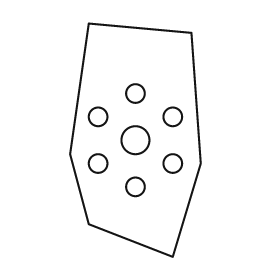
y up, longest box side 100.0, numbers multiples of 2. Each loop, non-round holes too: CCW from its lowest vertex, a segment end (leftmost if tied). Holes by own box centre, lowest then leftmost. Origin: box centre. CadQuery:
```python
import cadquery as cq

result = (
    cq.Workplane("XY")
    .moveTo(16.0, -50.0)
    .lineTo(28.0, -10.0)
    .lineTo(24.0, 46.0)
    .lineTo(-20.0, 50.0)
    .lineTo(-28.0, -6.0)
    .lineTo(-20.0, -36.0)
    .close()
    .moveTo(0.0, -20.0)
    .circle(4.0)
    .moveTo(-16.0, -10.0)
    .circle(4.0)
    .moveTo(16.0, -10.0)
    .circle(4.0)
    .moveTo(0.0, 0.0)
    .circle(6.0)
    .moveTo(-16.0, 10.0)
    .circle(4.0)
    .moveTo(16.0, 10.0)
    .circle(4.0)
    .moveTo(0.0, 20.0)
    .circle(4.0)
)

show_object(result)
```